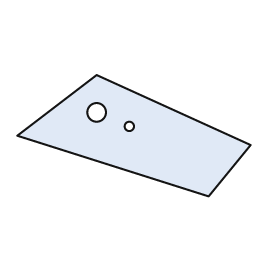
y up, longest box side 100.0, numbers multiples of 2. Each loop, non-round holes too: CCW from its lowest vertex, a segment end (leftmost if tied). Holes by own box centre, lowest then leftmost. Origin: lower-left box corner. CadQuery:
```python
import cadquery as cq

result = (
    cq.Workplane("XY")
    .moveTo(82.0, 0.0)
    .lineTo(100.0, 22.0)
    .lineTo(34.0, 52.0)
    .lineTo(0.0, 26.0)
    .close()
    .moveTo(48.0, 30.0)
    .circle(2.0)
    .moveTo(34.0, 36.0)
    .circle(4.0)
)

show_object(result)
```